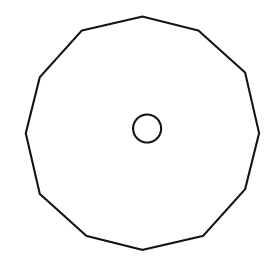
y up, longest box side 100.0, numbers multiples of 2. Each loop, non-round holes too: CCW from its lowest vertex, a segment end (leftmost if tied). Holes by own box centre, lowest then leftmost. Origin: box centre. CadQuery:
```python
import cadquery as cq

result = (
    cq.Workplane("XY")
    .moveTo(0.0, -50.0)
    .lineTo(26.0, -44.0)
    .lineTo(44.0, -24.0)
    .lineTo(50.0, 0.0)
    .lineTo(44.0, 26.0)
    .lineTo(24.0, 44.0)
    .lineTo(0.0, 50.0)
    .lineTo(-26.0, 44.0)
    .lineTo(-44.0, 24.0)
    .lineTo(-50.0, 0.0)
    .lineTo(-44.0, -26.0)
    .lineTo(-24.0, -44.0)
    .close()
    .moveTo(2.0, 2.0)
    .circle(6.0)
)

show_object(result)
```